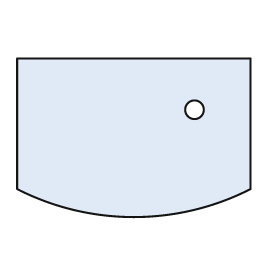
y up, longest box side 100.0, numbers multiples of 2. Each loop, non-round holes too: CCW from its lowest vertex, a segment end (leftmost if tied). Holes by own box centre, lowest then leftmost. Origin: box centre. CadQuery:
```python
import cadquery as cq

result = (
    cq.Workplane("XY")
    .moveTo(-50.0, -22.0)
    .threePointArc((0.0, -34.0), (50.0, -22.0))
    .lineTo(50.0, 34.0)
    .lineTo(-50.0, 34.0)
    .close()
    .moveTo(26.0, 12.0)
    .circle(4.0)
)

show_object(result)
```